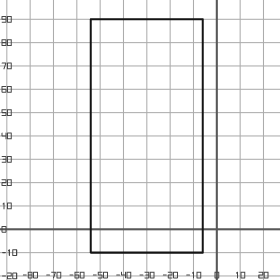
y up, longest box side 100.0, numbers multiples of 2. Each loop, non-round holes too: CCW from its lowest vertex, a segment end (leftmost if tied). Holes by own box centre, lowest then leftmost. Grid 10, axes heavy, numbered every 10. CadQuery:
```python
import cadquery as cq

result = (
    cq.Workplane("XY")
    .moveTo(-54.0, -10.0)
    .lineTo(-6.0, -10.0)
    .lineTo(-6.0, 90.0)
    .lineTo(-54.0, 90.0)
    .close()
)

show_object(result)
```